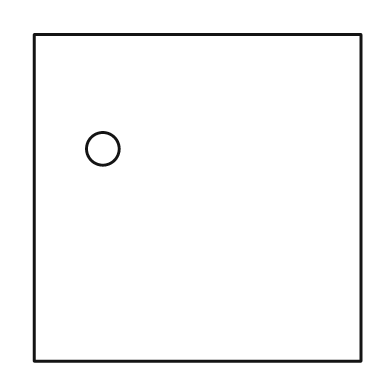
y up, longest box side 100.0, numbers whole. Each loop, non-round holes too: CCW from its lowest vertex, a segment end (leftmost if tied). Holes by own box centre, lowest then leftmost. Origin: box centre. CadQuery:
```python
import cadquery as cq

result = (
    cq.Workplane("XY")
    .moveTo(-50.0, -50.0)
    .lineTo(50.0, -50.0)
    .lineTo(50.0, 50.0)
    .lineTo(-50.0, 50.0)
    .close()
    .moveTo(-29.0, 15.0)
    .circle(5.0)
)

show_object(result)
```